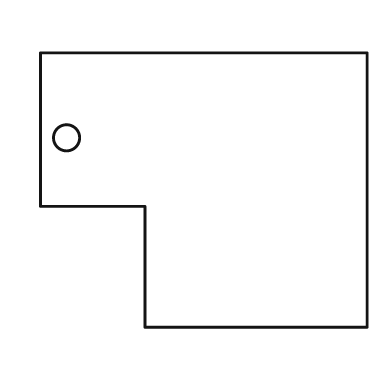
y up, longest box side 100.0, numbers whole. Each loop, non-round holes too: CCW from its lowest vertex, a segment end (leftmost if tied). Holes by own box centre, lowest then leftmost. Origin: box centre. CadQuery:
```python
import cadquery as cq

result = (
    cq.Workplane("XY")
    .moveTo(-18.0, -42.0)
    .lineTo(50.0, -42.0)
    .lineTo(50.0, 42.0)
    .lineTo(-50.0, 42.0)
    .lineTo(-50.0, -5.0)
    .lineTo(-18.0, -5.0)
    .close()
    .moveTo(-42.0, 16.0)
    .circle(4.0)
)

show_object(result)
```